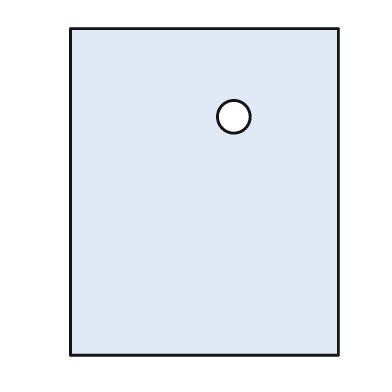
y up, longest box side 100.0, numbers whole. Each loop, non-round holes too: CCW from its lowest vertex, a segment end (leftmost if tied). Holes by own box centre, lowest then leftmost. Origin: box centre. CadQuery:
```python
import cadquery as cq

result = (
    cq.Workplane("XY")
    .moveTo(-41.0, -50.0)
    .lineTo(41.0, -50.0)
    .lineTo(41.0, 50.0)
    .lineTo(-41.0, 50.0)
    .close()
    .moveTo(9.0, 23.0)
    .circle(5.0)
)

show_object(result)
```